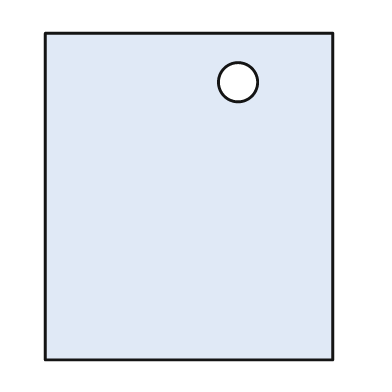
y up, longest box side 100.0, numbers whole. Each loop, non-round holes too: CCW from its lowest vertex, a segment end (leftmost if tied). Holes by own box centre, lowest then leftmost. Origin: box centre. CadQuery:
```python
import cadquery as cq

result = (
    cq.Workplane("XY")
    .moveTo(-44.0, -50.0)
    .lineTo(44.0, -50.0)
    .lineTo(44.0, 50.0)
    .lineTo(-44.0, 50.0)
    .close()
    .moveTo(15.0, 35.0)
    .circle(6.0)
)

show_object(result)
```